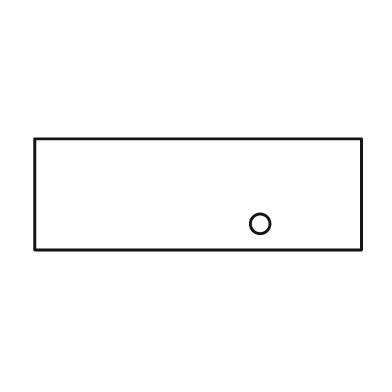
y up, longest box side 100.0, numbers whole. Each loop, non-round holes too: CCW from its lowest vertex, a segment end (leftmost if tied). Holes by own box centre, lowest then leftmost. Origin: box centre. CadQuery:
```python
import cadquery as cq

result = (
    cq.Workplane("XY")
    .moveTo(-50.0, -17.0)
    .lineTo(50.0, -17.0)
    .lineTo(50.0, 17.0)
    .lineTo(-50.0, 17.0)
    .close()
    .moveTo(19.0, -9.0)
    .circle(3.0)
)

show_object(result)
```